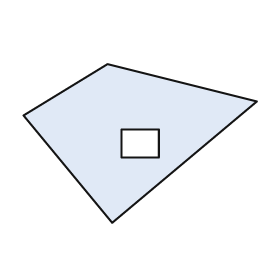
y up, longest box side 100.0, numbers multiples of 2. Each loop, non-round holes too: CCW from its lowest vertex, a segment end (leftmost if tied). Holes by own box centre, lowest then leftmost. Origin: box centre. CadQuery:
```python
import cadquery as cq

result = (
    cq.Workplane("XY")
    .moveTo(-12.0, -34.0)
    .lineTo(50.0, 18.0)
    .lineTo(-14.0, 34.0)
    .lineTo(-50.0, 12.0)
    .close()
    .moveTo(-8.0, -6.0)
    .lineTo(8.0, -6.0)
    .lineTo(8.0, 6.0)
    .lineTo(-8.0, 6.0)
    .close()
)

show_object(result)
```